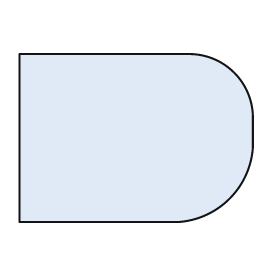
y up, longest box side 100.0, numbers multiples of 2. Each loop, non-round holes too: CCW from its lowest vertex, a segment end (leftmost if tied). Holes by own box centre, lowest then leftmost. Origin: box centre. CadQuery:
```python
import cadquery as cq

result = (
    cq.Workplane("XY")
    .moveTo(-50.0, -36.0)
    .lineTo(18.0, -36.0)
    .threePointArc((40.0, -26.0), (50.0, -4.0))
    .lineTo(50.0, 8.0)
    .threePointArc((42.0, 28.0), (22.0, 36.0))
    .lineTo(-50.0, 36.0)
    .close()
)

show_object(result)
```